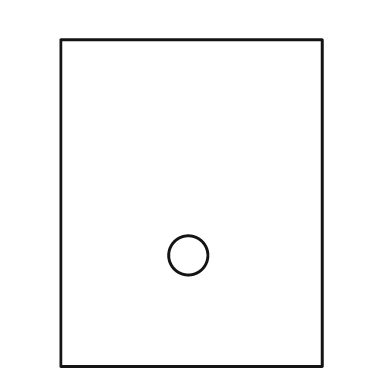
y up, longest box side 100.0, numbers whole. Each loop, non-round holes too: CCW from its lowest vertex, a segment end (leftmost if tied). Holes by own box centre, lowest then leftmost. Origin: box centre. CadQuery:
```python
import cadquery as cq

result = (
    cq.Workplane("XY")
    .moveTo(-40.0, -50.0)
    .lineTo(40.0, -50.0)
    .lineTo(40.0, 50.0)
    .lineTo(-40.0, 50.0)
    .close()
    .moveTo(-1.0, -16.0)
    .circle(6.0)
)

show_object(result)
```